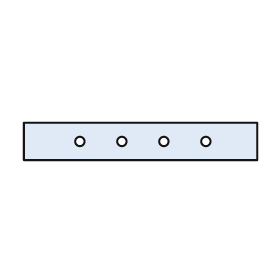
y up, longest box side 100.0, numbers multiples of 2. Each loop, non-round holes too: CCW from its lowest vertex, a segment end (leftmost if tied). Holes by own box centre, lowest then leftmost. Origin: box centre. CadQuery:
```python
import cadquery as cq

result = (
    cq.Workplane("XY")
    .moveTo(-50.0, -8.0)
    .lineTo(50.0, -8.0)
    .lineTo(50.0, 8.0)
    .lineTo(-50.0, 8.0)
    .close()
    .moveTo(-26.0, 0.0)
    .circle(2.0)
    .moveTo(-8.0, 0.0)
    .circle(2.0)
    .moveTo(10.0, 0.0)
    .circle(2.0)
    .moveTo(28.0, 0.0)
    .circle(2.0)
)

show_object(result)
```